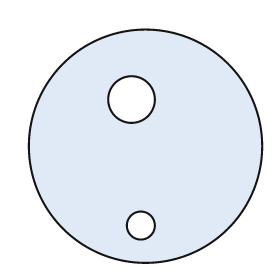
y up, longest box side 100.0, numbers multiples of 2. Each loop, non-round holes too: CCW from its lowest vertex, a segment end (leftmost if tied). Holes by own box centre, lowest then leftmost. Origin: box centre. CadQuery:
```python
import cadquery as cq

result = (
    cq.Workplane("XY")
    .moveTo(0.0, 0.0)
    .circle(50.0)
    .moveTo(-2.0, -34.0)
    .circle(6.0)
    .moveTo(-6.0, 20.0)
    .circle(10.0)
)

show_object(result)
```